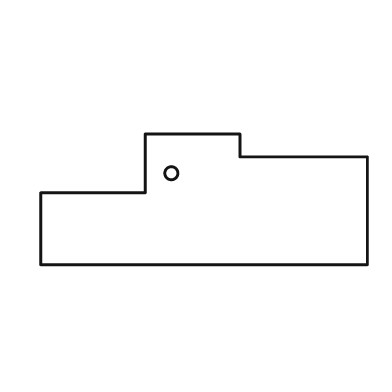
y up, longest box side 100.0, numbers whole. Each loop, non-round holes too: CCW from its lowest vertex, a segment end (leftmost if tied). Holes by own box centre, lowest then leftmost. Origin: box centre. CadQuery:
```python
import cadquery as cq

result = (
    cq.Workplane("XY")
    .moveTo(-50.0, -20.0)
    .lineTo(50.0, -20.0)
    .lineTo(50.0, 13.0)
    .lineTo(11.0, 13.0)
    .lineTo(11.0, 20.0)
    .lineTo(-18.0, 20.0)
    .lineTo(-18.0, 2.0)
    .lineTo(-50.0, 2.0)
    .close()
    .moveTo(-10.0, 8.0)
    .circle(2.0)
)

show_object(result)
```